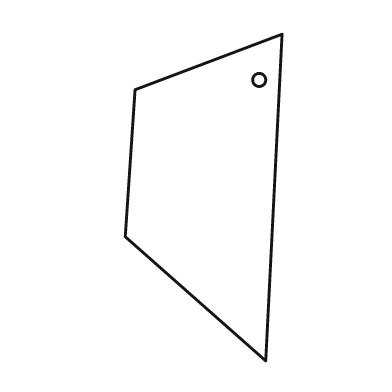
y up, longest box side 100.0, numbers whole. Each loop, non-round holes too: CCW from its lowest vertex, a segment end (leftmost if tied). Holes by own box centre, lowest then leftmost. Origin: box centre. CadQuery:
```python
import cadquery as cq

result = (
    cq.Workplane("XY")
    .moveTo(19.0, -50.0)
    .lineTo(24.0, 50.0)
    .lineTo(-21.0, 33.0)
    .lineTo(-24.0, -12.0)
    .close()
    .moveTo(17.0, 36.0)
    .circle(2.0)
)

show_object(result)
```